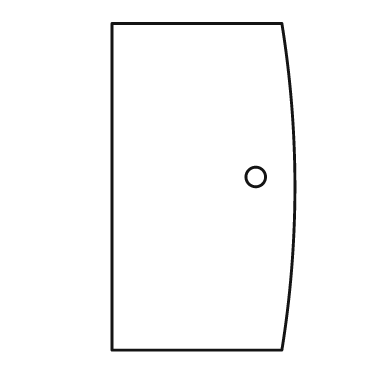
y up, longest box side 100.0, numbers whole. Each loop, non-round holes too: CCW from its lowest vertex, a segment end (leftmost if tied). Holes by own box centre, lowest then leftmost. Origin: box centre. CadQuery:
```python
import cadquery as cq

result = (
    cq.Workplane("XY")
    .moveTo(-28.0, -50.0)
    .lineTo(24.0, -50.0)
    .threePointArc((28.0, 0.0), (24.0, 50.0))
    .lineTo(-28.0, 50.0)
    .close()
    .moveTo(16.0, 3.0)
    .circle(3.0)
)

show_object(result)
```